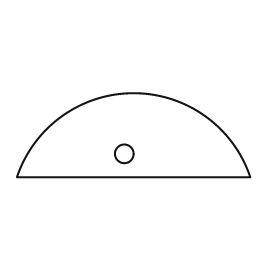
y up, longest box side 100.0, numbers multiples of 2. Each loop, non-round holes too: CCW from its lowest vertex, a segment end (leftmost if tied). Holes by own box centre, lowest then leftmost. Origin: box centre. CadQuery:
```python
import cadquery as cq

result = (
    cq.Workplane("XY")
    .moveTo(-50.0, -18.0)
    .lineTo(50.0, -18.0)
    .threePointArc((0.0, 18.0), (-50.0, -18.0))
    .close()
    .moveTo(-4.0, -8.0)
    .circle(4.0)
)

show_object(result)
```